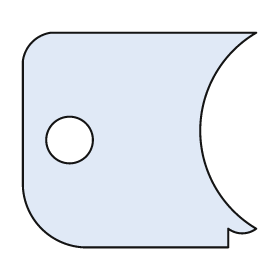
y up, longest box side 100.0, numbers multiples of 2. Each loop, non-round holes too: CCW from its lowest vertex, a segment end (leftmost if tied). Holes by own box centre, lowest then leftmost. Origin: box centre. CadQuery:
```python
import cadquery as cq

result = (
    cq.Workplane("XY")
    .moveTo(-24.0, -46.0)
    .lineTo(38.0, -46.0)
    .lineTo(38.0, -38.0)
    .threePointArc((44.0, -40.0), (50.0, -38.0))
    .threePointArc((26.0, 4.0), (50.0, 46.0))
    .lineTo(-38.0, 46.0)
    .threePointArc((-46.0, 42.0), (-50.0, 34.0))
    .lineTo(-50.0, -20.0)
    .threePointArc((-42.0, -38.0), (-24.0, -46.0))
    .close()
    .moveTo(-30.0, 0.0)
    .circle(10.0)
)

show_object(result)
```